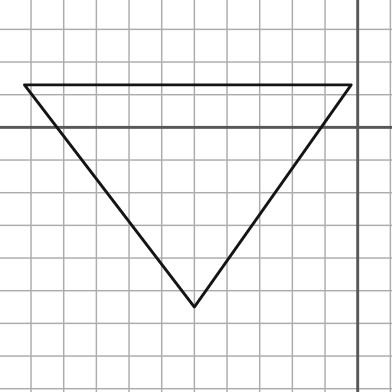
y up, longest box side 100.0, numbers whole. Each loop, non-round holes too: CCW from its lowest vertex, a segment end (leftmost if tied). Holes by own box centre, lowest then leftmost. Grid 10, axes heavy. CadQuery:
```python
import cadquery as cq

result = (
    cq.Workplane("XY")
    .moveTo(-50.0, -55.0)
    .lineTo(-2.0, 13.0)
    .lineTo(-102.0, 13.0)
    .close()
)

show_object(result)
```